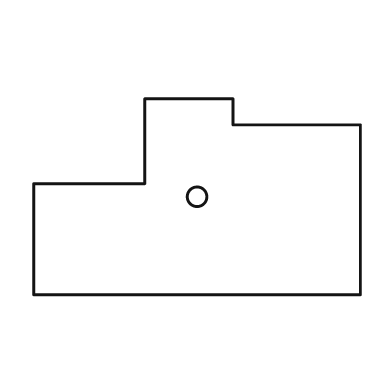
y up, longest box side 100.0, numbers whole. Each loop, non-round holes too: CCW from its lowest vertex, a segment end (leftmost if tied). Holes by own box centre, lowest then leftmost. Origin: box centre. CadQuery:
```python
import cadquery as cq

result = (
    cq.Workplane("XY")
    .moveTo(-50.0, -30.0)
    .lineTo(50.0, -30.0)
    .lineTo(50.0, 22.0)
    .lineTo(11.0, 22.0)
    .lineTo(11.0, 30.0)
    .lineTo(-16.0, 30.0)
    .lineTo(-16.0, 4.0)
    .lineTo(-50.0, 4.0)
    .close()
    .moveTo(0.0, 0.0)
    .circle(3.0)
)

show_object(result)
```